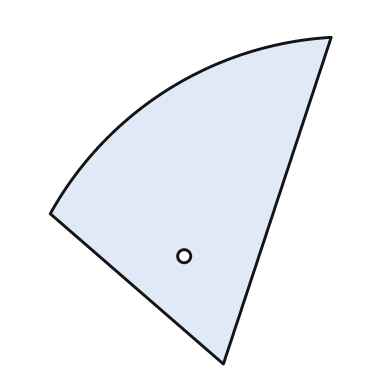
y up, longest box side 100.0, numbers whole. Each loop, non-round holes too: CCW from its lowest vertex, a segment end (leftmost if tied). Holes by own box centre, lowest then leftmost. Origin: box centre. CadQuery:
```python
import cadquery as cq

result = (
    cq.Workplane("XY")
    .moveTo(10.0, -50.0)
    .lineTo(43.0, 50.0)
    .threePointArc((-7.0, 34.0), (-43.0, -4.0))
    .close()
    .moveTo(-2.0, -17.0)
    .circle(2.0)
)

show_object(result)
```